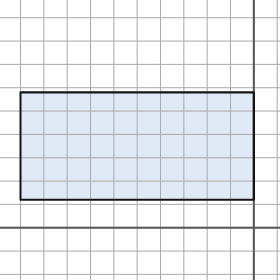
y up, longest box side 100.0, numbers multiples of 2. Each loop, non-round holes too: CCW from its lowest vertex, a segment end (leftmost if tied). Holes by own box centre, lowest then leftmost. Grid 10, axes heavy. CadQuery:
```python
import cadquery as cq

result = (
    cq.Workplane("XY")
    .moveTo(-100.0, 12.0)
    .lineTo(0.0, 12.0)
    .lineTo(0.0, 58.0)
    .lineTo(-100.0, 58.0)
    .close()
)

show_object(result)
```